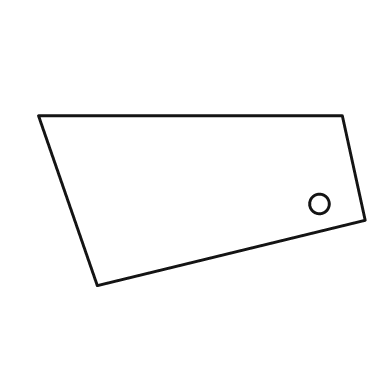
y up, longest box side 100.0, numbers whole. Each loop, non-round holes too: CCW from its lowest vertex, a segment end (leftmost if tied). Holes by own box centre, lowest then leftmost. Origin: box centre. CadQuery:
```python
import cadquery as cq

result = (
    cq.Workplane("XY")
    .moveTo(-32.0, -26.0)
    .lineTo(50.0, -6.0)
    .lineTo(43.0, 26.0)
    .lineTo(-50.0, 26.0)
    .close()
    .moveTo(36.0, -1.0)
    .circle(3.0)
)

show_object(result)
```